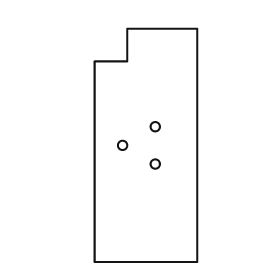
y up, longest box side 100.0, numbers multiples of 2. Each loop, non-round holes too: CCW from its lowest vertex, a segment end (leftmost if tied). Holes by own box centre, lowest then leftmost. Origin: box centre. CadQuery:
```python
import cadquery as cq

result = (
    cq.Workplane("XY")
    .moveTo(-22.0, -50.0)
    .lineTo(22.0, -50.0)
    .lineTo(22.0, 50.0)
    .lineTo(-8.0, 50.0)
    .lineTo(-8.0, 36.0)
    .lineTo(-22.0, 36.0)
    .close()
    .moveTo(4.0, -8.0)
    .circle(2.0)
    .moveTo(-10.0, 0.0)
    .circle(2.0)
    .moveTo(4.0, 8.0)
    .circle(2.0)
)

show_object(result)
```